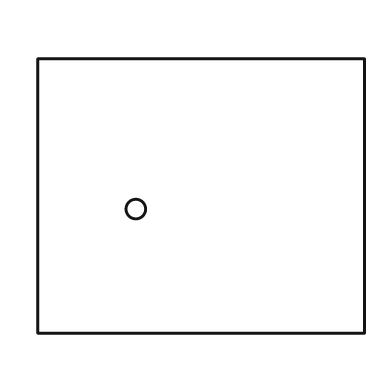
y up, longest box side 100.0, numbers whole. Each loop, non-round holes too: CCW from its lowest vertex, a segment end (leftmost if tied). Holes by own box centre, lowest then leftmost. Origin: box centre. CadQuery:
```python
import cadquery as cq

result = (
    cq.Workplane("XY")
    .moveTo(-50.0, -42.0)
    .lineTo(50.0, -42.0)
    .lineTo(50.0, 42.0)
    .lineTo(-50.0, 42.0)
    .close()
    .moveTo(-20.0, -4.0)
    .circle(3.0)
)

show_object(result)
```